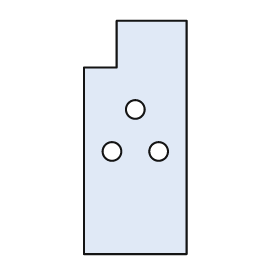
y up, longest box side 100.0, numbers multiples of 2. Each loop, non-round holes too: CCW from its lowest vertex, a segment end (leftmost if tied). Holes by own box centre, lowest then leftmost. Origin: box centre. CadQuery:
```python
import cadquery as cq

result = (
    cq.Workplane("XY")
    .moveTo(-22.0, -50.0)
    .lineTo(22.0, -50.0)
    .lineTo(22.0, 50.0)
    .lineTo(-8.0, 50.0)
    .lineTo(-8.0, 30.0)
    .lineTo(-22.0, 30.0)
    .close()
    .moveTo(-10.0, -6.0)
    .circle(4.0)
    .moveTo(10.0, -6.0)
    .circle(4.0)
    .moveTo(0.0, 12.0)
    .circle(4.0)
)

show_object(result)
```